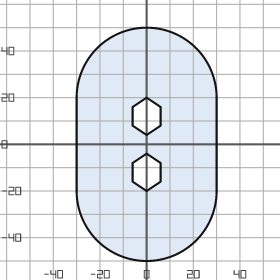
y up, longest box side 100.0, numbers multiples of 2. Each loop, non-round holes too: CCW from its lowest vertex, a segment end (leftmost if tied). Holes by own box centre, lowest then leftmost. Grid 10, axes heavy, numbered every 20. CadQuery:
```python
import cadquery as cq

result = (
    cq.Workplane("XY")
    .moveTo(-30.0, -20.0)
    .threePointArc((0.0, -50.0), (30.0, -20.0))
    .lineTo(30.0, 20.0)
    .threePointArc((0.0, 50.0), (-30.0, 20.0))
    .close()
    .moveTo(0.0, -20.0)
    .lineTo(6.0, -16.0)
    .lineTo(6.0, -8.0)
    .lineTo(0.0, -4.0)
    .lineTo(-6.0, -8.0)
    .lineTo(-6.0, -16.0)
    .close()
    .moveTo(0.0, 4.0)
    .lineTo(6.0, 8.0)
    .lineTo(6.0, 16.0)
    .lineTo(0.0, 20.0)
    .lineTo(-6.0, 16.0)
    .lineTo(-6.0, 8.0)
    .close()
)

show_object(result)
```